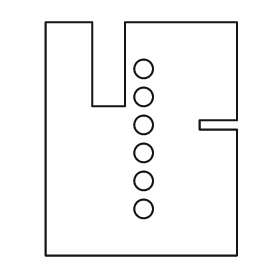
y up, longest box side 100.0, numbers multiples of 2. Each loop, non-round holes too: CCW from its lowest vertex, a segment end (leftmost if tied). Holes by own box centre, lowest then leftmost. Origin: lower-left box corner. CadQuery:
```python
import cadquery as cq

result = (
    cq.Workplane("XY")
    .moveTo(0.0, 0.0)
    .lineTo(82.0, 0.0)
    .lineTo(82.0, 54.0)
    .lineTo(66.0, 54.0)
    .lineTo(66.0, 58.0)
    .lineTo(82.0, 58.0)
    .lineTo(82.0, 100.0)
    .lineTo(34.0, 100.0)
    .lineTo(34.0, 64.0)
    .lineTo(20.0, 64.0)
    .lineTo(20.0, 100.0)
    .lineTo(0.0, 100.0)
    .close()
    .moveTo(42.0, 20.0)
    .circle(4.0)
    .moveTo(42.0, 32.0)
    .circle(4.0)
    .moveTo(42.0, 44.0)
    .circle(4.0)
    .moveTo(42.0, 56.0)
    .circle(4.0)
    .moveTo(42.0, 68.0)
    .circle(4.0)
    .moveTo(42.0, 80.0)
    .circle(4.0)
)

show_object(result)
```